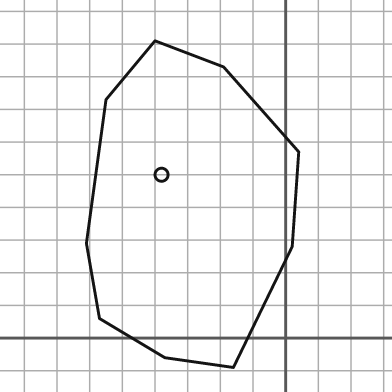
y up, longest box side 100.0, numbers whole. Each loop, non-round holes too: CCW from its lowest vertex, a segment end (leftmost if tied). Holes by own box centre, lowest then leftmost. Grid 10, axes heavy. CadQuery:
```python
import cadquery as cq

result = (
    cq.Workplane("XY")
    .moveTo(-16.0, -9.0)
    .lineTo(2.0, 28.0)
    .lineTo(4.0, 57.0)
    .lineTo(-19.0, 83.0)
    .lineTo(-40.0, 91.0)
    .lineTo(-55.0, 73.0)
    .lineTo(-61.0, 29.0)
    .lineTo(-57.0, 6.0)
    .lineTo(-37.0, -6.0)
    .close()
    .moveTo(-38.0, 50.0)
    .circle(2.0)
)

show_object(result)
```